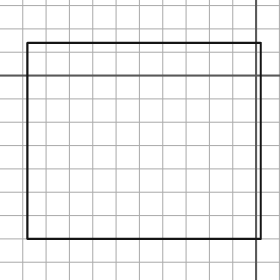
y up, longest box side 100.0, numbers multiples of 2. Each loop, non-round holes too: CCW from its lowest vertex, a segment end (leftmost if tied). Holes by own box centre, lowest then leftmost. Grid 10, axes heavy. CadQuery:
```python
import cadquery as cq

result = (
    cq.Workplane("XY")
    .moveTo(-98.0, -70.0)
    .lineTo(2.0, -70.0)
    .lineTo(2.0, 14.0)
    .lineTo(-98.0, 14.0)
    .close()
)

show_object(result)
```